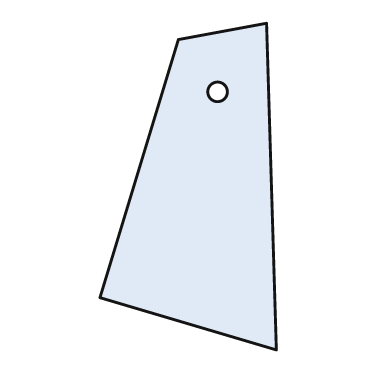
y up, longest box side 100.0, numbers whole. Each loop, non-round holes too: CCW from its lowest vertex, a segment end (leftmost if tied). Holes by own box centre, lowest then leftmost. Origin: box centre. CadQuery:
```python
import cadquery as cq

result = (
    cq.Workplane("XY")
    .moveTo(27.0, -50.0)
    .lineTo(24.0, 50.0)
    .lineTo(-3.0, 45.0)
    .lineTo(-27.0, -34.0)
    .close()
    .moveTo(9.0, 29.0)
    .circle(3.0)
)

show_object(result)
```